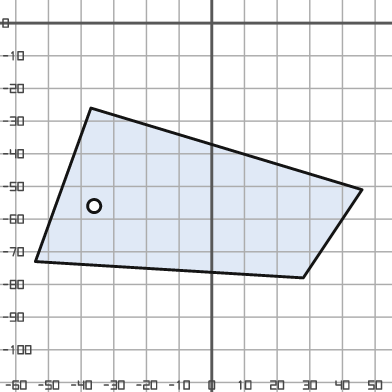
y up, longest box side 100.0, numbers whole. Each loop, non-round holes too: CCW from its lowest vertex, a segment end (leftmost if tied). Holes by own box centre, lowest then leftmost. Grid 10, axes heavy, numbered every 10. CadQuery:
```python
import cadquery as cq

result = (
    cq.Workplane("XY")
    .moveTo(28.0, -78.0)
    .lineTo(46.0, -51.0)
    .lineTo(-37.0, -26.0)
    .lineTo(-54.0, -73.0)
    .close()
    .moveTo(-36.0, -56.0)
    .circle(2.0)
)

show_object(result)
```